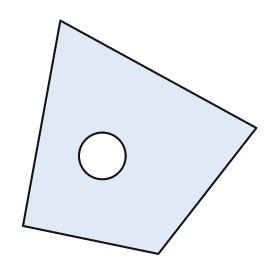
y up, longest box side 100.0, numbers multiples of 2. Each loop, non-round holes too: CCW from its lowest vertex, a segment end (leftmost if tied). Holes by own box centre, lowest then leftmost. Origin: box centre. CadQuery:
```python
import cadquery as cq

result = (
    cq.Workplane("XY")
    .moveTo(8.0, -50.0)
    .lineTo(50.0, 4.0)
    .lineTo(-34.0, 50.0)
    .lineTo(-50.0, -38.0)
    .close()
    .moveTo(-16.0, -8.0)
    .circle(10.0)
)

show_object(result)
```